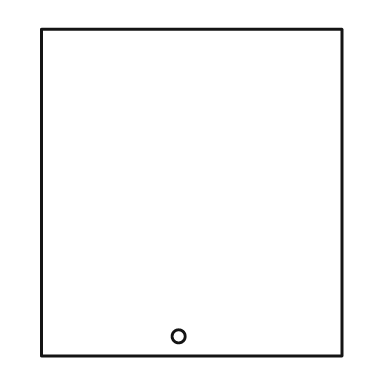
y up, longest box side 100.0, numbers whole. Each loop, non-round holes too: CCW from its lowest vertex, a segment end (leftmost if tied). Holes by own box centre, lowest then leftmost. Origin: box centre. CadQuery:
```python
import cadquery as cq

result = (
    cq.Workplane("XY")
    .moveTo(-46.0, -50.0)
    .lineTo(46.0, -50.0)
    .lineTo(46.0, 50.0)
    .lineTo(-46.0, 50.0)
    .close()
    .moveTo(-4.0, -44.0)
    .circle(2.0)
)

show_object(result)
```